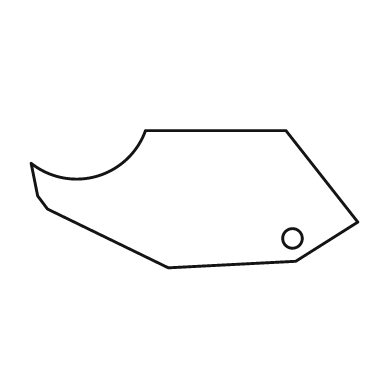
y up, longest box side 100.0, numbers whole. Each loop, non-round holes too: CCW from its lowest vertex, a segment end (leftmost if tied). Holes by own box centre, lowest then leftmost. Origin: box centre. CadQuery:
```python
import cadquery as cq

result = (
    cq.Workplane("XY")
    .moveTo(-8.0, -21.0)
    .lineTo(31.0, -19.0)
    .lineTo(50.0, -7.0)
    .lineTo(28.0, 21.0)
    .lineTo(-15.0, 21.0)
    .threePointArc((-30.0, 7.0), (-50.0, 11.0))
    .lineTo(-48.0, 1.0)
    .lineTo(-45.0, -3.0)
    .close()
    .moveTo(30.0, -12.0)
    .circle(3.0)
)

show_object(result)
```